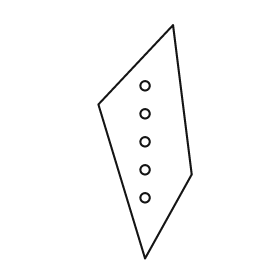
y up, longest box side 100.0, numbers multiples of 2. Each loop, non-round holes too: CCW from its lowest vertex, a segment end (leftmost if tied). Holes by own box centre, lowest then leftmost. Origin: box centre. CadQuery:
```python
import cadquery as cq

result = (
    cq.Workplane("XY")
    .moveTo(0.0, -50.0)
    .lineTo(20.0, -14.0)
    .lineTo(12.0, 50.0)
    .lineTo(-20.0, 16.0)
    .close()
    .moveTo(0.0, -24.0)
    .circle(2.0)
    .moveTo(0.0, -12.0)
    .circle(2.0)
    .moveTo(0.0, 0.0)
    .circle(2.0)
    .moveTo(0.0, 12.0)
    .circle(2.0)
    .moveTo(0.0, 24.0)
    .circle(2.0)
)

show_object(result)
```